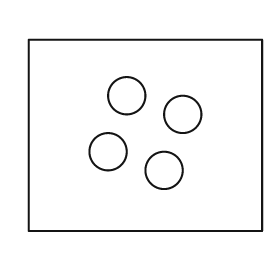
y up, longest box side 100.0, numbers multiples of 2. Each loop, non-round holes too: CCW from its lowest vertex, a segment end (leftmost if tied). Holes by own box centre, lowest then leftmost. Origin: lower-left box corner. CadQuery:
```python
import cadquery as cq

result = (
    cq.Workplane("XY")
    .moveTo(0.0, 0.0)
    .lineTo(100.0, 0.0)
    .lineTo(100.0, 82.0)
    .lineTo(0.0, 82.0)
    .close()
    .moveTo(58.0, 26.0)
    .circle(8.0)
    .moveTo(34.0, 34.0)
    .circle(8.0)
    .moveTo(66.0, 50.0)
    .circle(8.0)
    .moveTo(42.0, 58.0)
    .circle(8.0)
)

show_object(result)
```